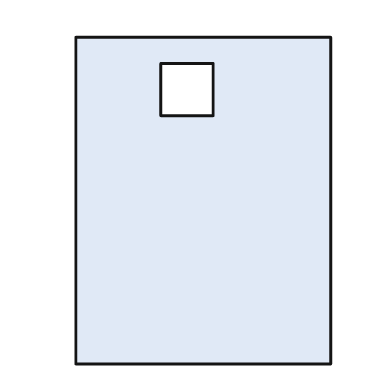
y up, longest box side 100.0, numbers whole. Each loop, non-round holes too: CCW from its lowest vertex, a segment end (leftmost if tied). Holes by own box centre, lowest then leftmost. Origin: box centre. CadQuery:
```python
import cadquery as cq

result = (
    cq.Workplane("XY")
    .moveTo(-39.0, -50.0)
    .lineTo(39.0, -50.0)
    .lineTo(39.0, 50.0)
    .lineTo(-39.0, 50.0)
    .close()
    .moveTo(-13.0, 26.0)
    .lineTo(3.0, 26.0)
    .lineTo(3.0, 42.0)
    .lineTo(-13.0, 42.0)
    .close()
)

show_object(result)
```